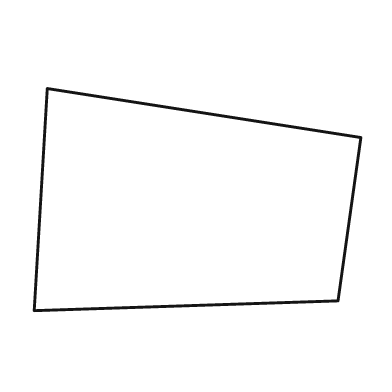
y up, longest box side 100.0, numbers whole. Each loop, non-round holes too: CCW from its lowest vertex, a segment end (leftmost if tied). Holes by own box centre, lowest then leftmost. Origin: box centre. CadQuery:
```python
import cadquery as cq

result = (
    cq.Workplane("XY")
    .moveTo(-50.0, -34.0)
    .lineTo(43.0, -31.0)
    .lineTo(50.0, 19.0)
    .lineTo(-46.0, 34.0)
    .close()
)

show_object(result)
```